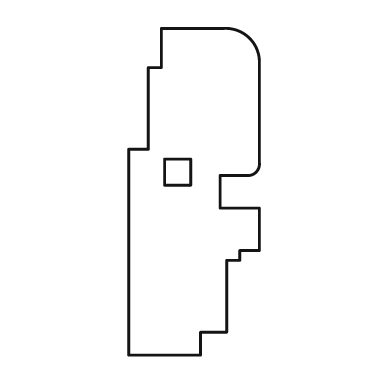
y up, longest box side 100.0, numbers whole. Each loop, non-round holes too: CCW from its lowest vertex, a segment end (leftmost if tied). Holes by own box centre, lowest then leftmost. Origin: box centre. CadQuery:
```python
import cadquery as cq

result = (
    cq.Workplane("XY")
    .moveTo(-20.0, -50.0)
    .lineTo(2.0, -50.0)
    .lineTo(2.0, -43.0)
    .lineTo(10.0, -43.0)
    .lineTo(10.0, -21.0)
    .lineTo(14.0, -21.0)
    .lineTo(14.0, -18.0)
    .lineTo(20.0, -18.0)
    .lineTo(20.0, -5.0)
    .lineTo(8.0, -5.0)
    .lineTo(8.0, 5.0)
    .lineTo(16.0, 5.0)
    .threePointArc((19.0, 6.0), (20.0, 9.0))
    .lineTo(20.0, 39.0)
    .threePointArc((17.0, 47.0), (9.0, 50.0))
    .lineTo(-10.0, 50.0)
    .lineTo(-10.0, 38.0)
    .lineTo(-14.0, 38.0)
    .lineTo(-14.0, 13.0)
    .lineTo(-20.0, 13.0)
    .close()
    .moveTo(-9.0, 2.0)
    .lineTo(-1.0, 2.0)
    .lineTo(-1.0, 10.0)
    .lineTo(-9.0, 10.0)
    .close()
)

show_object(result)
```